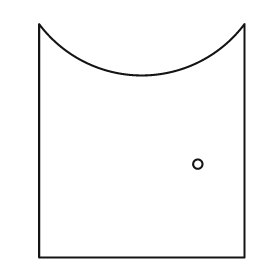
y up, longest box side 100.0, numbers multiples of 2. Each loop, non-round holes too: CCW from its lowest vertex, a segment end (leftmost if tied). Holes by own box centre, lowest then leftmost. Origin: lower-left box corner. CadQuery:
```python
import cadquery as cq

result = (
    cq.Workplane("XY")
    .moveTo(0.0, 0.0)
    .lineTo(88.0, 0.0)
    .lineTo(88.0, 100.0)
    .threePointArc((44.0, 78.0), (0.0, 100.0))
    .close()
    .moveTo(68.0, 40.0)
    .circle(2.0)
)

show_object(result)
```